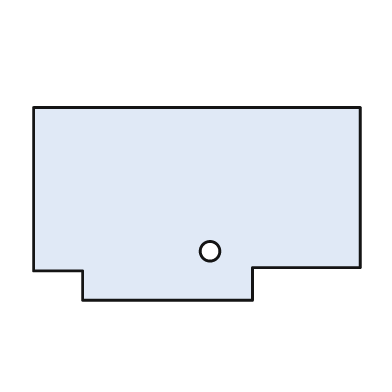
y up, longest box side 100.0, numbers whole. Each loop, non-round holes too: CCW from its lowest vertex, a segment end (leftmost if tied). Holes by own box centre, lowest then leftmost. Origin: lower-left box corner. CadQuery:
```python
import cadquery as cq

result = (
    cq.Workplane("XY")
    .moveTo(15.0, 0.0)
    .lineTo(67.0, 0.0)
    .lineTo(67.0, 10.0)
    .lineTo(100.0, 10.0)
    .lineTo(100.0, 59.0)
    .lineTo(0.0, 59.0)
    .lineTo(0.0, 9.0)
    .lineTo(15.0, 9.0)
    .close()
    .moveTo(54.0, 15.0)
    .circle(3.0)
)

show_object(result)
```